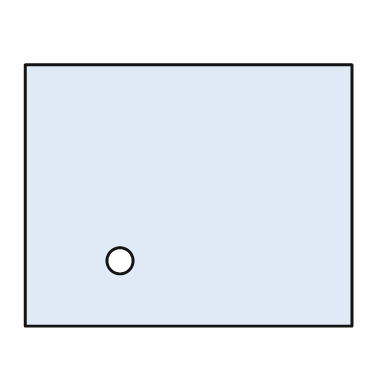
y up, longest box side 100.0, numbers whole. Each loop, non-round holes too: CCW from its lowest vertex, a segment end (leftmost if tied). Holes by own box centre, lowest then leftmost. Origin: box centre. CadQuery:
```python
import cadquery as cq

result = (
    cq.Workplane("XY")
    .moveTo(-50.0, -40.0)
    .lineTo(50.0, -40.0)
    .lineTo(50.0, 40.0)
    .lineTo(-50.0, 40.0)
    .close()
    .moveTo(-21.0, -20.0)
    .circle(4.0)
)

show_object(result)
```